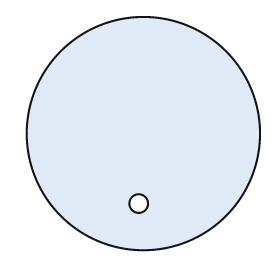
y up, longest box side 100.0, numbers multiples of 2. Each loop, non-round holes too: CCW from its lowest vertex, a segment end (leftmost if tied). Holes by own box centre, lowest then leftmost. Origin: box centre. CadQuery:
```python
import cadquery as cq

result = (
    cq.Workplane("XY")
    .moveTo(0.0, 0.0)
    .circle(50.0)
    .moveTo(-2.0, -30.0)
    .circle(4.0)
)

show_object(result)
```